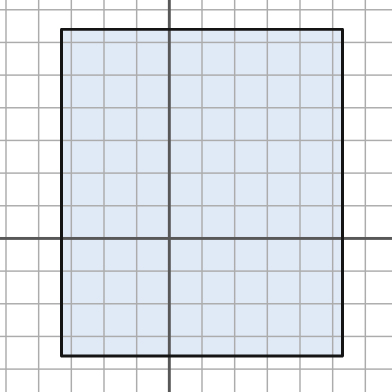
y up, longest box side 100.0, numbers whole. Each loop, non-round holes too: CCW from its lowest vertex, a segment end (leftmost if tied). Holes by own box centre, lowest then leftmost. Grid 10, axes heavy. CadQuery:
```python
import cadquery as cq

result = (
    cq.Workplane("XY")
    .moveTo(-33.0, -36.0)
    .lineTo(53.0, -36.0)
    .lineTo(53.0, 64.0)
    .lineTo(-33.0, 64.0)
    .close()
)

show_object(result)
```